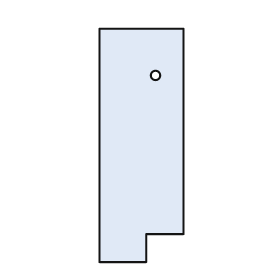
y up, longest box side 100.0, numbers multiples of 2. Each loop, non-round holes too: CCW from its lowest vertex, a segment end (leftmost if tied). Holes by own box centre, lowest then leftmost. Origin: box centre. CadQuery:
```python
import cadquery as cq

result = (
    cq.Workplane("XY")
    .moveTo(-18.0, -50.0)
    .lineTo(2.0, -50.0)
    .lineTo(2.0, -38.0)
    .lineTo(18.0, -38.0)
    .lineTo(18.0, 50.0)
    .lineTo(-18.0, 50.0)
    .close()
    .moveTo(6.0, 30.0)
    .circle(2.0)
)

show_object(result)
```